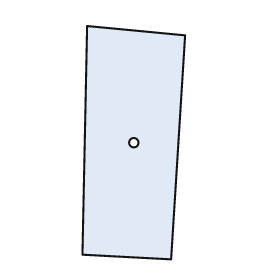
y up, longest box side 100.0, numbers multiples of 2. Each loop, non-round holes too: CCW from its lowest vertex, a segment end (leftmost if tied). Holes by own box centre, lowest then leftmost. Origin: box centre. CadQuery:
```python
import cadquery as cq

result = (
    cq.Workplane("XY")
    .moveTo(16.0, -50.0)
    .lineTo(22.0, 46.0)
    .lineTo(-20.0, 50.0)
    .lineTo(-22.0, -48.0)
    .close()
    .moveTo(0.0, 0.0)
    .circle(2.0)
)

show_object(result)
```